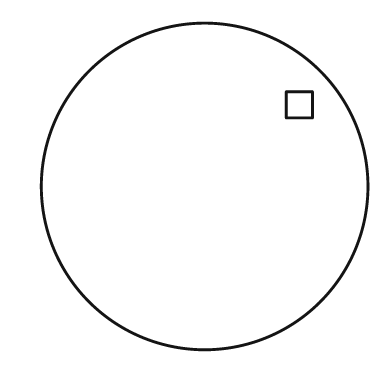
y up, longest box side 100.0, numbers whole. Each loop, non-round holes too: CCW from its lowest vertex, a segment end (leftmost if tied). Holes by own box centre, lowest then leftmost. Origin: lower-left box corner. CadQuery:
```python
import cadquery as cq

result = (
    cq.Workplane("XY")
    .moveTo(50.0, 50.0)
    .circle(50.0)
    .moveTo(75.0, 71.0)
    .lineTo(83.0, 71.0)
    .lineTo(83.0, 79.0)
    .lineTo(75.0, 79.0)
    .close()
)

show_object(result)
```